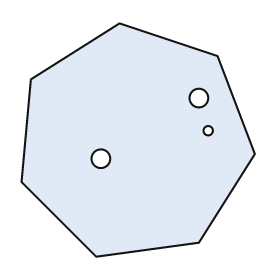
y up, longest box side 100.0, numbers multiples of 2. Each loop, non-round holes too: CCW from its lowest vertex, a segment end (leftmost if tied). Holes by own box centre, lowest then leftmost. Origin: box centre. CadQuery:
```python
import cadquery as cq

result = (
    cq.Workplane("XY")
    .moveTo(-18.0, -50.0)
    .lineTo(26.0, -44.0)
    .lineTo(50.0, -6.0)
    .lineTo(34.0, 36.0)
    .lineTo(-8.0, 50.0)
    .lineTo(-46.0, 26.0)
    .lineTo(-50.0, -18.0)
    .close()
    .moveTo(-16.0, -8.0)
    .circle(4.0)
    .moveTo(30.0, 4.0)
    .circle(2.0)
    .moveTo(26.0, 18.0)
    .circle(4.0)
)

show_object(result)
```